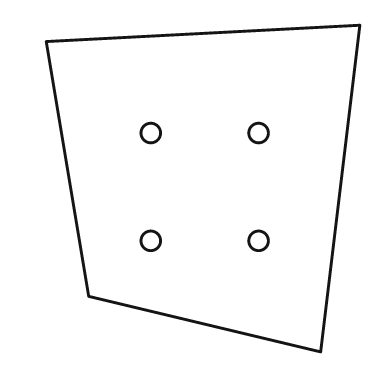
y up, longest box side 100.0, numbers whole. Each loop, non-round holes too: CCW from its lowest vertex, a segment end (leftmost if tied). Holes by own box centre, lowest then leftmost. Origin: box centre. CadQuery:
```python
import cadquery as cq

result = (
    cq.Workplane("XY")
    .moveTo(36.0, -50.0)
    .lineTo(48.0, 50.0)
    .lineTo(-48.0, 45.0)
    .lineTo(-35.0, -33.0)
    .close()
    .moveTo(-16.0, -16.0)
    .circle(3.0)
    .moveTo(17.0, -16.0)
    .circle(3.0)
    .moveTo(-16.0, 17.0)
    .circle(3.0)
    .moveTo(17.0, 17.0)
    .circle(3.0)
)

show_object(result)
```